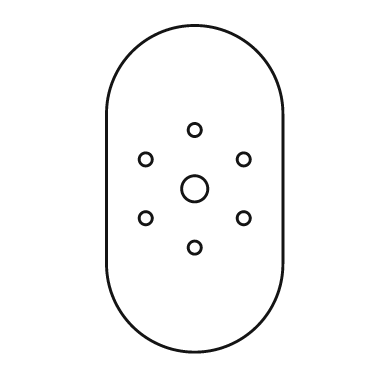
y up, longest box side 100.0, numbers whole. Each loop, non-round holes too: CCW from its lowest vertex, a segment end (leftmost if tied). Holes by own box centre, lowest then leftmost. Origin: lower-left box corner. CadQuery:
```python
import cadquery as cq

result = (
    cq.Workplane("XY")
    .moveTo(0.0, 27.0)
    .threePointArc((27.0, 0.0), (54.0, 27.0))
    .lineTo(54.0, 73.0)
    .threePointArc((27.0, 100.0), (0.0, 73.0))
    .close()
    .moveTo(27.0, 32.0)
    .circle(2.0)
    .moveTo(12.0, 41.0)
    .circle(2.0)
    .moveTo(42.0, 41.0)
    .circle(2.0)
    .moveTo(27.0, 50.0)
    .circle(4.0)
    .moveTo(12.0, 59.0)
    .circle(2.0)
    .moveTo(42.0, 59.0)
    .circle(2.0)
    .moveTo(27.0, 68.0)
    .circle(2.0)
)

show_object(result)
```